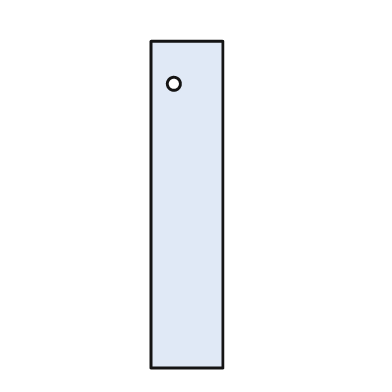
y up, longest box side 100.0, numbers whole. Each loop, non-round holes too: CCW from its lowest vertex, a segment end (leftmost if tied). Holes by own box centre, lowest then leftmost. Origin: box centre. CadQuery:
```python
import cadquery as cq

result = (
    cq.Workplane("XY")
    .moveTo(-11.0, -50.0)
    .lineTo(11.0, -50.0)
    .lineTo(11.0, 50.0)
    .lineTo(-11.0, 50.0)
    .close()
    .moveTo(-4.0, 37.0)
    .circle(2.0)
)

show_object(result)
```